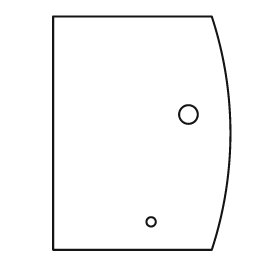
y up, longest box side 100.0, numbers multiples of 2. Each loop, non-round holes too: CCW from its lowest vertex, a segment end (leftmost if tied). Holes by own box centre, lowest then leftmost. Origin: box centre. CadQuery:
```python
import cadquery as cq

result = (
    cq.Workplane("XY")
    .moveTo(-38.0, -50.0)
    .lineTo(30.0, -50.0)
    .threePointArc((38.0, 0.0), (30.0, 50.0))
    .lineTo(-38.0, 50.0)
    .close()
    .moveTo(4.0, -38.0)
    .circle(2.0)
    .moveTo(20.0, 8.0)
    .circle(4.0)
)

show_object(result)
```